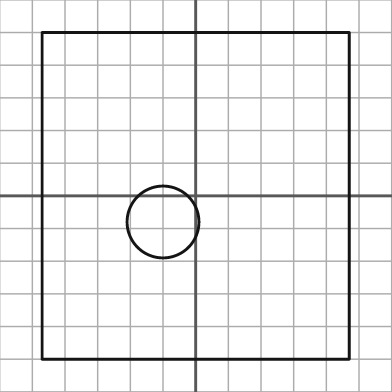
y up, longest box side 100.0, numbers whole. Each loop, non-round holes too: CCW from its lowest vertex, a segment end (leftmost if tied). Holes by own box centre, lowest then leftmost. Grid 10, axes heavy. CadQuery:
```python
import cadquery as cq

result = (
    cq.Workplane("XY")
    .moveTo(-47.0, -50.0)
    .lineTo(47.0, -50.0)
    .lineTo(47.0, 50.0)
    .lineTo(-47.0, 50.0)
    .close()
    .moveTo(-10.0, -8.0)
    .circle(11.0)
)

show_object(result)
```